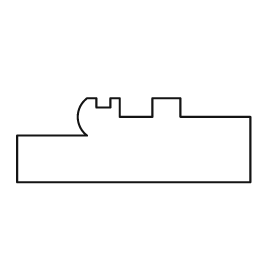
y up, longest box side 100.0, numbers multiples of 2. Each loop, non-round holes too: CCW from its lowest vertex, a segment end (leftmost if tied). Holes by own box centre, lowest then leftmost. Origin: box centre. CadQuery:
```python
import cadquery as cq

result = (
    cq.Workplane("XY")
    .moveTo(-50.0, -18.0)
    .lineTo(50.0, -18.0)
    .lineTo(50.0, 10.0)
    .lineTo(20.0, 10.0)
    .lineTo(20.0, 18.0)
    .lineTo(8.0, 18.0)
    .lineTo(8.0, 10.0)
    .lineTo(-6.0, 10.0)
    .lineTo(-6.0, 18.0)
    .lineTo(-10.0, 18.0)
    .lineTo(-10.0, 14.0)
    .lineTo(-16.0, 14.0)
    .lineTo(-16.0, 18.0)
    .lineTo(-20.0, 18.0)
    .threePointArc((-24.0, 10.0), (-20.0, 2.0))
    .lineTo(-50.0, 2.0)
    .close()
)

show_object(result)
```